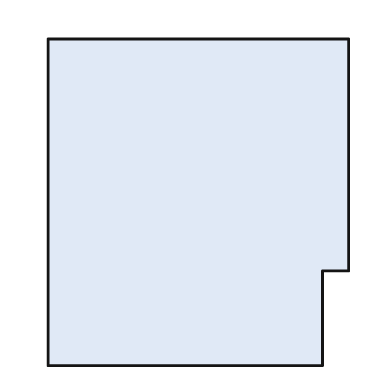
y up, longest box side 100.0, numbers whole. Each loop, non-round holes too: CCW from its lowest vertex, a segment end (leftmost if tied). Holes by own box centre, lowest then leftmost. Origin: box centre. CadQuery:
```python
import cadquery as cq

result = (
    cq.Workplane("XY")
    .moveTo(-46.0, -50.0)
    .lineTo(38.0, -50.0)
    .lineTo(38.0, -21.0)
    .lineTo(46.0, -21.0)
    .lineTo(46.0, 50.0)
    .lineTo(-46.0, 50.0)
    .close()
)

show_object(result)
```